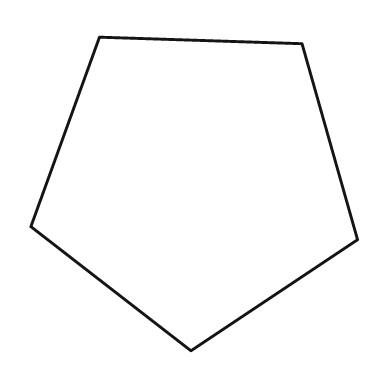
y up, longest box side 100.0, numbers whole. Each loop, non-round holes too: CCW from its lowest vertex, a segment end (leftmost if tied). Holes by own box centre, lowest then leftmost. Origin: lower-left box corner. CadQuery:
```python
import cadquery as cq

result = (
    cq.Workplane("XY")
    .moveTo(49.0, 0.0)
    .lineTo(100.0, 34.0)
    .lineTo(83.0, 94.0)
    .lineTo(21.0, 96.0)
    .lineTo(0.0, 38.0)
    .close()
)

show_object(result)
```